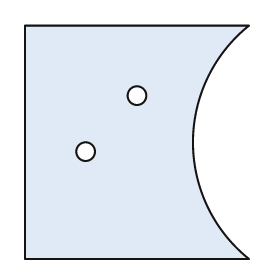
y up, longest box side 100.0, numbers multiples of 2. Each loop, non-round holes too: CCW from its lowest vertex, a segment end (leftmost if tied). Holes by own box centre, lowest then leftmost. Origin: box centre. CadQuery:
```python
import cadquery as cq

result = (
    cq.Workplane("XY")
    .moveTo(-48.0, -50.0)
    .lineTo(48.0, -50.0)
    .threePointArc((24.0, 0.0), (48.0, 50.0))
    .lineTo(-48.0, 50.0)
    .close()
    .moveTo(-22.0, -4.0)
    .circle(4.0)
    .moveTo(0.0, 20.0)
    .circle(4.0)
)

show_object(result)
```